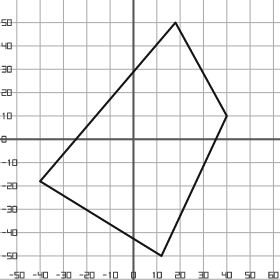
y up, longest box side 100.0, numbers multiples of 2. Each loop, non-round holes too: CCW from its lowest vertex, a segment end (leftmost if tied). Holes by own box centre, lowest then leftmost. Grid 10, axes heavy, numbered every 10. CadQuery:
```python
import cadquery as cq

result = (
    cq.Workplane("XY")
    .moveTo(12.0, -50.0)
    .lineTo(40.0, 10.0)
    .lineTo(18.0, 50.0)
    .lineTo(-40.0, -18.0)
    .close()
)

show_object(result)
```